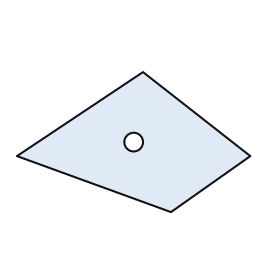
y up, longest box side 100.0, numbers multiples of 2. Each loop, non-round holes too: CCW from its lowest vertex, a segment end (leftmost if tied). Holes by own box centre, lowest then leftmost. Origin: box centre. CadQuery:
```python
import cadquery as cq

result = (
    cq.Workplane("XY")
    .moveTo(16.0, -30.0)
    .lineTo(50.0, -6.0)
    .lineTo(4.0, 30.0)
    .lineTo(-50.0, -6.0)
    .close()
    .moveTo(0.0, 0.0)
    .circle(4.0)
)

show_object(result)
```